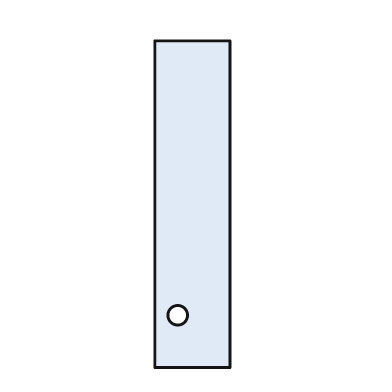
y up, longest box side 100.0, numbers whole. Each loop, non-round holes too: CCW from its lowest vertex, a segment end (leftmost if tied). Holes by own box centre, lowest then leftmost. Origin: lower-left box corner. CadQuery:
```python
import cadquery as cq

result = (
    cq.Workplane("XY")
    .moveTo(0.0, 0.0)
    .lineTo(23.0, 0.0)
    .lineTo(23.0, 100.0)
    .lineTo(0.0, 100.0)
    .close()
    .moveTo(7.0, 16.0)
    .circle(3.0)
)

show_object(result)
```